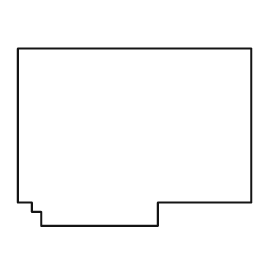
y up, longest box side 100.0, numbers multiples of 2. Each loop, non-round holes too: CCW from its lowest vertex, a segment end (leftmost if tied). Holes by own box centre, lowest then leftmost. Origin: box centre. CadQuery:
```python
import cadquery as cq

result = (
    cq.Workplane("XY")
    .moveTo(-40.0, -38.0)
    .lineTo(10.0, -38.0)
    .lineTo(10.0, -28.0)
    .lineTo(50.0, -28.0)
    .lineTo(50.0, 38.0)
    .lineTo(-50.0, 38.0)
    .lineTo(-50.0, -28.0)
    .lineTo(-44.0, -28.0)
    .lineTo(-44.0, -32.0)
    .lineTo(-40.0, -32.0)
    .close()
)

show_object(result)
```